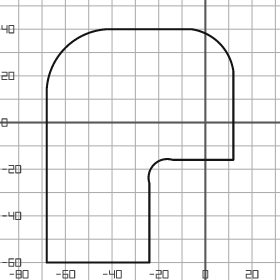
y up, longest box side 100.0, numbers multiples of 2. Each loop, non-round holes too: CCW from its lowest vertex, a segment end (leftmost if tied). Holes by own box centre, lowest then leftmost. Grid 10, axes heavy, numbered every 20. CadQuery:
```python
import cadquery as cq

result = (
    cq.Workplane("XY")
    .moveTo(-68.0, -60.0)
    .lineTo(-24.0, -60.0)
    .lineTo(-24.0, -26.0)
    .threePointArc((-22.0, -18.0), (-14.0, -16.0))
    .lineTo(12.0, -16.0)
    .lineTo(12.0, 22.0)
    .threePointArc((6.0, 34.0), (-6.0, 40.0))
    .lineTo(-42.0, 40.0)
    .threePointArc((-60.0, 32.0), (-68.0, 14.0))
    .close()
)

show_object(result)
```